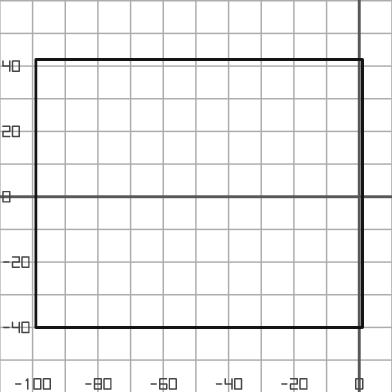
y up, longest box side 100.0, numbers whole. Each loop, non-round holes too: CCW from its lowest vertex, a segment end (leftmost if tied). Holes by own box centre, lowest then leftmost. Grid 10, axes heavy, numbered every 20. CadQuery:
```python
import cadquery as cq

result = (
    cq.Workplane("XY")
    .moveTo(-99.0, -40.0)
    .lineTo(1.0, -40.0)
    .lineTo(1.0, 42.0)
    .lineTo(-99.0, 42.0)
    .close()
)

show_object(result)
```